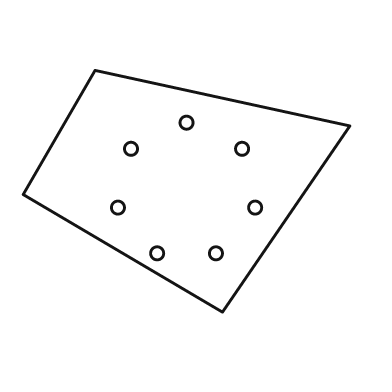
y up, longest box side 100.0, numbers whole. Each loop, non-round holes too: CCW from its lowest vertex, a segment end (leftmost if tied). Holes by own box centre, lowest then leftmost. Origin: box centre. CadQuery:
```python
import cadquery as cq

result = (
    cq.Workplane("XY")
    .moveTo(11.0, -37.0)
    .lineTo(50.0, 20.0)
    .lineTo(-28.0, 37.0)
    .lineTo(-50.0, -1.0)
    .close()
    .moveTo(-9.0, -19.0)
    .circle(2.0)
    .moveTo(9.0, -19.0)
    .circle(2.0)
    .moveTo(-21.0, -5.0)
    .circle(2.0)
    .moveTo(21.0, -5.0)
    .circle(2.0)
    .moveTo(-17.0, 13.0)
    .circle(2.0)
    .moveTo(17.0, 13.0)
    .circle(2.0)
    .moveTo(0.0, 21.0)
    .circle(2.0)
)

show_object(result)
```